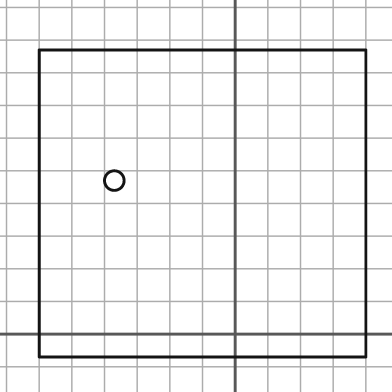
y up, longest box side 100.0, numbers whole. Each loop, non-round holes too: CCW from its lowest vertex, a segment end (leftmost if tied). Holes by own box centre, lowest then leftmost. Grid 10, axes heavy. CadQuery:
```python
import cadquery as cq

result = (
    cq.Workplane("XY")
    .moveTo(-60.0, -7.0)
    .lineTo(40.0, -7.0)
    .lineTo(40.0, 87.0)
    .lineTo(-60.0, 87.0)
    .close()
    .moveTo(-37.0, 47.0)
    .circle(3.0)
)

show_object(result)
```